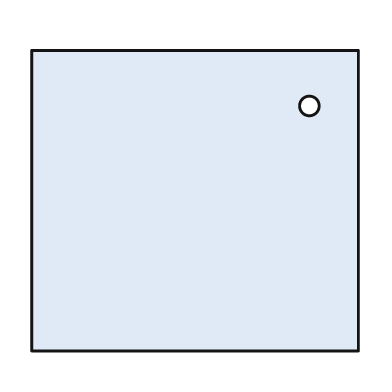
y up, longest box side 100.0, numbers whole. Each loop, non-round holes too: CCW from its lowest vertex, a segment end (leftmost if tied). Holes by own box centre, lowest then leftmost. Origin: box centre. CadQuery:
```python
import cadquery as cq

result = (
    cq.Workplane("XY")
    .moveTo(-50.0, -46.0)
    .lineTo(50.0, -46.0)
    .lineTo(50.0, 46.0)
    .lineTo(-50.0, 46.0)
    .close()
    .moveTo(35.0, 29.0)
    .circle(3.0)
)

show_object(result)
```